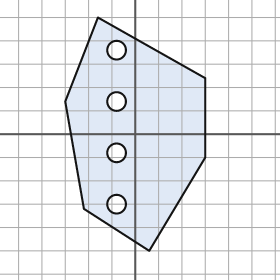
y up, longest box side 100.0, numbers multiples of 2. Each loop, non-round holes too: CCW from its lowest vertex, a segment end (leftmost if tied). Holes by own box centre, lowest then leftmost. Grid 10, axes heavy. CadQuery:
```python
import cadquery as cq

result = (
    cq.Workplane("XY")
    .moveTo(6.0, -50.0)
    .lineTo(30.0, -10.0)
    .lineTo(30.0, 24.0)
    .lineTo(-16.0, 50.0)
    .lineTo(-30.0, 14.0)
    .lineTo(-22.0, -32.0)
    .close()
    .moveTo(-8.0, -30.0)
    .circle(4.0)
    .moveTo(-8.0, -8.0)
    .circle(4.0)
    .moveTo(-8.0, 14.0)
    .circle(4.0)
    .moveTo(-8.0, 36.0)
    .circle(4.0)
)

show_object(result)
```